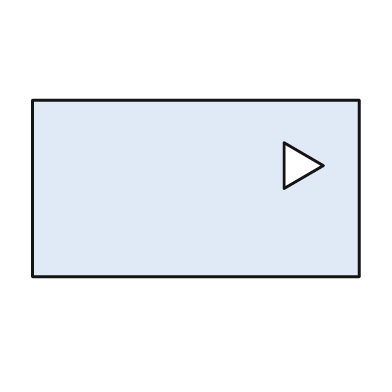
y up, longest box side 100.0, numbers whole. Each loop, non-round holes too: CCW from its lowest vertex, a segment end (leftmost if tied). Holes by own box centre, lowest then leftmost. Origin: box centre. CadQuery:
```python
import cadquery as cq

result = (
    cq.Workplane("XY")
    .moveTo(-50.0, -27.0)
    .lineTo(50.0, -27.0)
    .lineTo(50.0, 27.0)
    .lineTo(-50.0, 27.0)
    .close()
    .moveTo(27.0, 0.0)
    .lineTo(39.0, 7.0)
    .lineTo(27.0, 14.0)
    .close()
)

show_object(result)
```